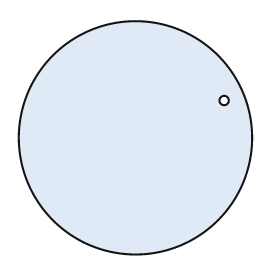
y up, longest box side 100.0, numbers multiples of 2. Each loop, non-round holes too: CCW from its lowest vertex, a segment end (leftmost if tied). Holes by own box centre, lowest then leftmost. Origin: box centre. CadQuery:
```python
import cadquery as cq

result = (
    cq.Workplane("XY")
    .moveTo(0.0, 0.0)
    .circle(50.0)
    .moveTo(38.0, 16.0)
    .circle(2.0)
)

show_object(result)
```